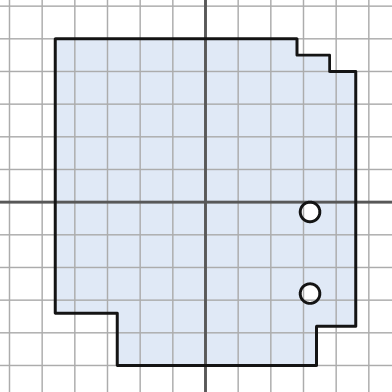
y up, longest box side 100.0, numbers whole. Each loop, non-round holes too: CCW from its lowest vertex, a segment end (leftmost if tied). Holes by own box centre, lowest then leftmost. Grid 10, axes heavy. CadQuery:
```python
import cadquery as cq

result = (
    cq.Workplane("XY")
    .moveTo(-27.0, -50.0)
    .lineTo(34.0, -50.0)
    .lineTo(34.0, -38.0)
    .lineTo(46.0, -38.0)
    .lineTo(46.0, 40.0)
    .lineTo(38.0, 40.0)
    .lineTo(38.0, 45.0)
    .lineTo(28.0, 45.0)
    .lineTo(28.0, 50.0)
    .lineTo(-46.0, 50.0)
    .lineTo(-46.0, -34.0)
    .lineTo(-27.0, -34.0)
    .close()
    .moveTo(32.0, -28.0)
    .circle(3.0)
    .moveTo(32.0, -3.0)
    .circle(3.0)
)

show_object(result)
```